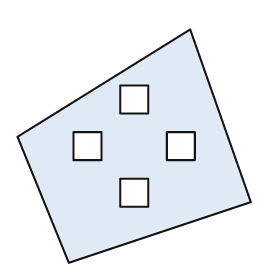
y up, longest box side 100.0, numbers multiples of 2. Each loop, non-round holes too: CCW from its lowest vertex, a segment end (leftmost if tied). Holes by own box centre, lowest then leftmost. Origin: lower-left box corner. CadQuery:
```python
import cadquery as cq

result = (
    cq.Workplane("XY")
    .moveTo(22.0, 0.0)
    .lineTo(100.0, 26.0)
    .lineTo(74.0, 100.0)
    .lineTo(0.0, 54.0)
    .close()
    .moveTo(44.0, 24.0)
    .lineTo(56.0, 24.0)
    .lineTo(56.0, 36.0)
    .lineTo(44.0, 36.0)
    .close()
    .moveTo(24.0, 44.0)
    .lineTo(36.0, 44.0)
    .lineTo(36.0, 56.0)
    .lineTo(24.0, 56.0)
    .close()
    .moveTo(64.0, 44.0)
    .lineTo(76.0, 44.0)
    .lineTo(76.0, 56.0)
    .lineTo(64.0, 56.0)
    .close()
    .moveTo(44.0, 64.0)
    .lineTo(56.0, 64.0)
    .lineTo(56.0, 76.0)
    .lineTo(44.0, 76.0)
    .close()
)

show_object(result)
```